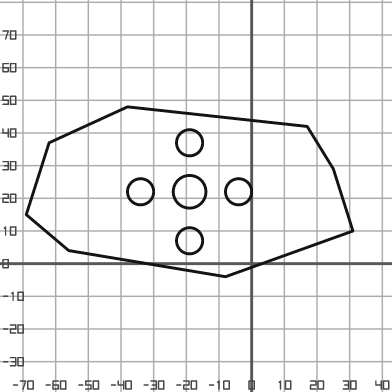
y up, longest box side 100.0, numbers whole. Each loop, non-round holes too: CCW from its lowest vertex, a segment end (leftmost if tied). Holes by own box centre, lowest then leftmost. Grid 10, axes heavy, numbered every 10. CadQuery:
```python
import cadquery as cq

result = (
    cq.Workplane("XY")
    .moveTo(-8.0, -4.0)
    .lineTo(31.0, 10.0)
    .lineTo(25.0, 29.0)
    .lineTo(17.0, 42.0)
    .lineTo(-38.0, 48.0)
    .lineTo(-62.0, 37.0)
    .lineTo(-69.0, 15.0)
    .lineTo(-56.0, 4.0)
    .close()
    .moveTo(-19.0, 7.0)
    .circle(4.0)
    .moveTo(-34.0, 22.0)
    .circle(4.0)
    .moveTo(-19.0, 22.0)
    .circle(5.0)
    .moveTo(-4.0, 22.0)
    .circle(4.0)
    .moveTo(-19.0, 37.0)
    .circle(4.0)
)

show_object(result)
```